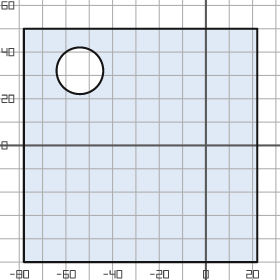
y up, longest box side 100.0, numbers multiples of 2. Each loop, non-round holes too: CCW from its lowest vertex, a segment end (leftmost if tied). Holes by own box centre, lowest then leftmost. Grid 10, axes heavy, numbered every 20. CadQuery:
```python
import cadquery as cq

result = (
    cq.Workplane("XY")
    .moveTo(-78.0, -50.0)
    .lineTo(22.0, -50.0)
    .lineTo(22.0, 50.0)
    .lineTo(-78.0, 50.0)
    .close()
    .moveTo(-54.0, 32.0)
    .circle(10.0)
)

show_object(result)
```